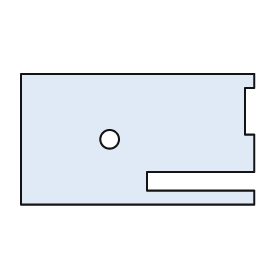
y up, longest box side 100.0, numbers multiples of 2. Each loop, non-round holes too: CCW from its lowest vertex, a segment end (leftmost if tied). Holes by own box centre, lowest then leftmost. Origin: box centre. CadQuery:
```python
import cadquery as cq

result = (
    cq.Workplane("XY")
    .moveTo(-50.0, -28.0)
    .lineTo(50.0, -28.0)
    .lineTo(50.0, -22.0)
    .lineTo(4.0, -22.0)
    .lineTo(4.0, -14.0)
    .lineTo(50.0, -14.0)
    .lineTo(50.0, 2.0)
    .lineTo(46.0, 2.0)
    .lineTo(46.0, 22.0)
    .lineTo(50.0, 22.0)
    .lineTo(50.0, 28.0)
    .lineTo(-50.0, 28.0)
    .close()
    .moveTo(-12.0, 0.0)
    .circle(4.0)
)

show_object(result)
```